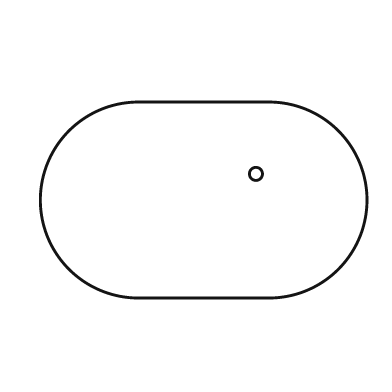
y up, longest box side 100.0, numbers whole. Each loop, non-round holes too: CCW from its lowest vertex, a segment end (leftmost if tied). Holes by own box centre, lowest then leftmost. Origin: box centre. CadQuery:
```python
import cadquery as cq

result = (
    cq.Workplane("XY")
    .moveTo(-20.0, -30.0)
    .lineTo(20.0, -30.0)
    .threePointArc((50.0, 0.0), (20.0, 30.0))
    .lineTo(-20.0, 30.0)
    .threePointArc((-50.0, 0.0), (-20.0, -30.0))
    .close()
    .moveTo(16.0, 8.0)
    .circle(2.0)
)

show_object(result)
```